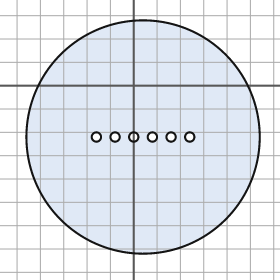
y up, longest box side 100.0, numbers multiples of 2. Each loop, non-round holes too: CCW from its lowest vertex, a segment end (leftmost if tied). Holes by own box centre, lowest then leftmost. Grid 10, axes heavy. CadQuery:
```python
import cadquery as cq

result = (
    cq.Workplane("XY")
    .moveTo(4.0, -22.0)
    .circle(50.0)
    .moveTo(-16.0, -22.0)
    .circle(2.0)
    .moveTo(-8.0, -22.0)
    .circle(2.0)
    .moveTo(0.0, -22.0)
    .circle(2.0)
    .moveTo(8.0, -22.0)
    .circle(2.0)
    .moveTo(16.0, -22.0)
    .circle(2.0)
    .moveTo(24.0, -22.0)
    .circle(2.0)
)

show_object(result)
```